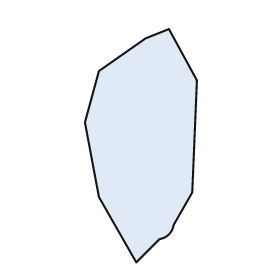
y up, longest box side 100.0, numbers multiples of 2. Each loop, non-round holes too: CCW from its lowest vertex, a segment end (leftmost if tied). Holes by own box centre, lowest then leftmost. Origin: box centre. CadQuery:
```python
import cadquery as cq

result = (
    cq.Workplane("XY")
    .moveTo(-2.0, -50.0)
    .lineTo(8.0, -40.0)
    .threePointArc((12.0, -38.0), (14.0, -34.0))
    .lineTo(22.0, -20.0)
    .lineTo(24.0, 28.0)
    .lineTo(12.0, 50.0)
    .lineTo(2.0, 46.0)
    .lineTo(-18.0, 32.0)
    .lineTo(-24.0, 10.0)
    .lineTo(-18.0, -22.0)
    .close()
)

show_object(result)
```